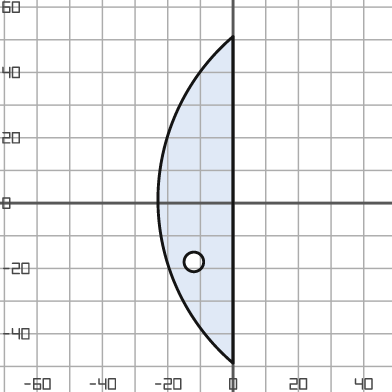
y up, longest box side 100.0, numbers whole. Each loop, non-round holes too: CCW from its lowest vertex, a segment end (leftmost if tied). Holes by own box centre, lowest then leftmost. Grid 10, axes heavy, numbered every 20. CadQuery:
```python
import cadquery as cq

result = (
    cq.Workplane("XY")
    .moveTo(0.0, -49.0)
    .lineTo(0.0, 51.0)
    .threePointArc((-23.0, 1.0), (0.0, -49.0))
    .close()
    .moveTo(-12.0, -18.0)
    .circle(3.0)
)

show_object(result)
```